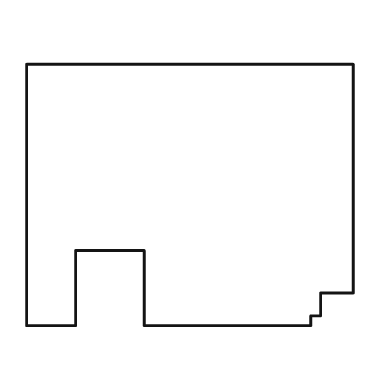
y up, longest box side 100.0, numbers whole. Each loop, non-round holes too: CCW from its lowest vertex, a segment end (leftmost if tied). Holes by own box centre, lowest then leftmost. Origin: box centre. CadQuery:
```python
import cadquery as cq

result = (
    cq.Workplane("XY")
    .moveTo(-50.0, -40.0)
    .lineTo(-35.0, -40.0)
    .lineTo(-35.0, -17.0)
    .lineTo(-14.0, -17.0)
    .lineTo(-14.0, -40.0)
    .lineTo(37.0, -40.0)
    .lineTo(37.0, -37.0)
    .lineTo(40.0, -37.0)
    .lineTo(40.0, -30.0)
    .lineTo(50.0, -30.0)
    .lineTo(50.0, 40.0)
    .lineTo(-50.0, 40.0)
    .close()
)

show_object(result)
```